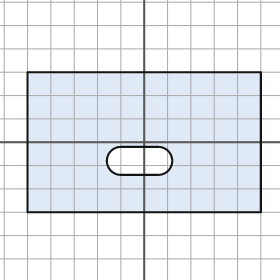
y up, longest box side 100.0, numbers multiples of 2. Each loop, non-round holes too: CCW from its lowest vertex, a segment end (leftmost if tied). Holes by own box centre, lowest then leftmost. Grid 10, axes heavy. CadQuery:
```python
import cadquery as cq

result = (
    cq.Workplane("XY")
    .moveTo(-50.0, -30.0)
    .lineTo(50.0, -30.0)
    .lineTo(50.0, 30.0)
    .lineTo(-50.0, 30.0)
    .close()
    .moveTo(-10.0, -14.0)
    .lineTo(6.0, -14.0)
    .threePointArc((12.0, -8.0), (6.0, -2.0))
    .lineTo(-10.0, -2.0)
    .threePointArc((-16.0, -8.0), (-10.0, -14.0))
    .close()
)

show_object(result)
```